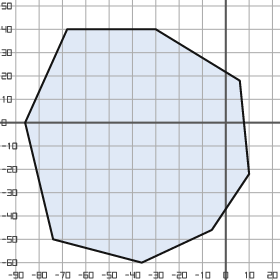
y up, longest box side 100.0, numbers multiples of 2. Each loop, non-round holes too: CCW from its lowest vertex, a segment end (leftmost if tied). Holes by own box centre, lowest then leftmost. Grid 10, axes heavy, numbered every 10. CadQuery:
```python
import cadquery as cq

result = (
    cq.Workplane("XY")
    .moveTo(-36.0, -60.0)
    .lineTo(-6.0, -46.0)
    .lineTo(10.0, -22.0)
    .lineTo(6.0, 18.0)
    .lineTo(-30.0, 40.0)
    .lineTo(-68.0, 40.0)
    .lineTo(-86.0, 0.0)
    .lineTo(-74.0, -50.0)
    .close()
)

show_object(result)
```